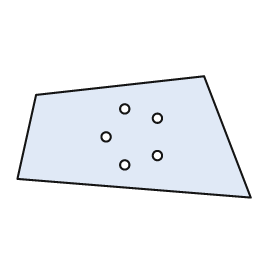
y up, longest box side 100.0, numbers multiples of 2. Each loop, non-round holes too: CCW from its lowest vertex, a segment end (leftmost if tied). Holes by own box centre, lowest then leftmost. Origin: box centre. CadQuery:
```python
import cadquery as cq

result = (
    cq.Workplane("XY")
    .moveTo(50.0, -26.0)
    .lineTo(30.0, 26.0)
    .lineTo(-42.0, 18.0)
    .lineTo(-50.0, -18.0)
    .close()
    .moveTo(-4.0, -12.0)
    .circle(2.0)
    .moveTo(10.0, -8.0)
    .circle(2.0)
    .moveTo(-12.0, 0.0)
    .circle(2.0)
    .moveTo(10.0, 8.0)
    .circle(2.0)
    .moveTo(-4.0, 12.0)
    .circle(2.0)
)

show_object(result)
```